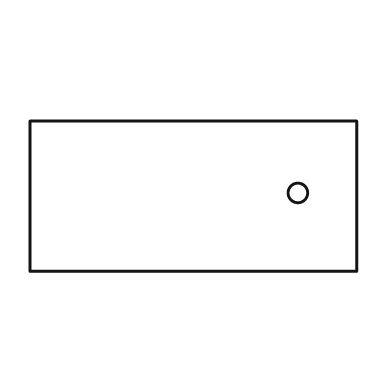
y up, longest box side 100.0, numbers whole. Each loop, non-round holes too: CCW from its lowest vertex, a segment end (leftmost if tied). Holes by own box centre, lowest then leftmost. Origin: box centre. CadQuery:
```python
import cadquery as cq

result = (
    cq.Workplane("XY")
    .moveTo(-50.0, -23.0)
    .lineTo(50.0, -23.0)
    .lineTo(50.0, 23.0)
    .lineTo(-50.0, 23.0)
    .close()
    .moveTo(32.0, 1.0)
    .circle(3.0)
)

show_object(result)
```